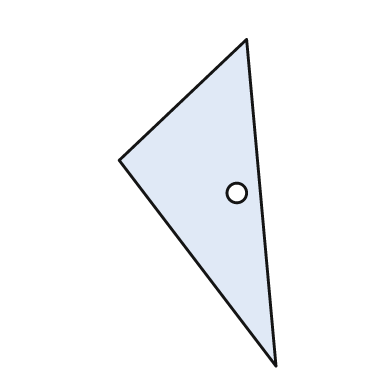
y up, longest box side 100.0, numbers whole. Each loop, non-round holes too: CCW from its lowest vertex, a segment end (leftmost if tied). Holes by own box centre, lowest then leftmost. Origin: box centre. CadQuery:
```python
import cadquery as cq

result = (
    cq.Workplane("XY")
    .moveTo(24.0, -50.0)
    .lineTo(15.0, 50.0)
    .lineTo(-24.0, 13.0)
    .close()
    .moveTo(12.0, 3.0)
    .circle(3.0)
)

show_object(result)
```